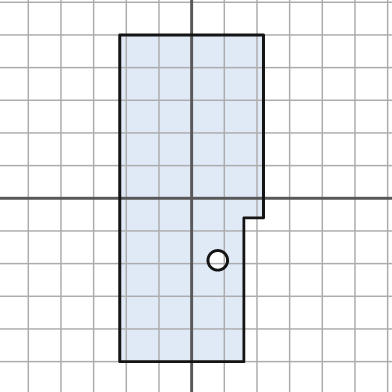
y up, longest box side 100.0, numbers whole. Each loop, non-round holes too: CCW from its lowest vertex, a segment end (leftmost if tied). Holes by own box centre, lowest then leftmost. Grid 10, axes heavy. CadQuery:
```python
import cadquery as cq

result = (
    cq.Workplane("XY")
    .moveTo(-22.0, -50.0)
    .lineTo(16.0, -50.0)
    .lineTo(16.0, -6.0)
    .lineTo(22.0, -6.0)
    .lineTo(22.0, 50.0)
    .lineTo(-22.0, 50.0)
    .close()
    .moveTo(8.0, -19.0)
    .circle(3.0)
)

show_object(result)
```